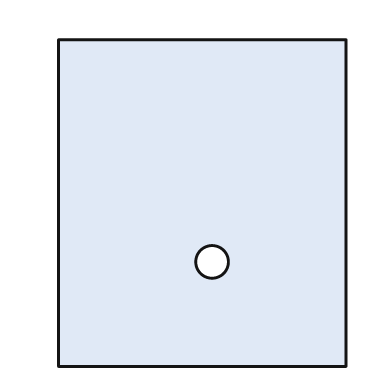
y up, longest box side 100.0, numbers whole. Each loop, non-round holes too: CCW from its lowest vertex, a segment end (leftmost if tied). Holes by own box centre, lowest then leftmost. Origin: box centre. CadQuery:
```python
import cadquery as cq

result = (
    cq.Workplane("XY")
    .moveTo(-44.0, -50.0)
    .lineTo(44.0, -50.0)
    .lineTo(44.0, 50.0)
    .lineTo(-44.0, 50.0)
    .close()
    .moveTo(3.0, -18.0)
    .circle(5.0)
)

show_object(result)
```